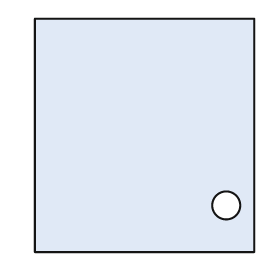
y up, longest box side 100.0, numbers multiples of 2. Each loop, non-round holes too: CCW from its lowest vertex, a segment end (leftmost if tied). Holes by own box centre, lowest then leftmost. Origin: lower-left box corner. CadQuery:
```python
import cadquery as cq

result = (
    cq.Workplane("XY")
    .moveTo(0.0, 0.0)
    .lineTo(94.0, 0.0)
    .lineTo(94.0, 100.0)
    .lineTo(0.0, 100.0)
    .close()
    .moveTo(82.0, 20.0)
    .circle(6.0)
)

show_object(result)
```